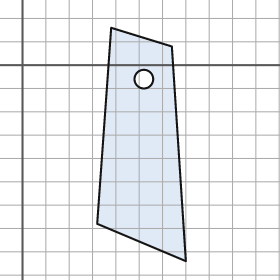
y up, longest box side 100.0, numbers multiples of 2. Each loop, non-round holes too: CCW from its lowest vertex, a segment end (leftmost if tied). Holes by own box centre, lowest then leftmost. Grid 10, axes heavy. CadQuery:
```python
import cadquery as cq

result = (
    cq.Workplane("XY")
    .moveTo(70.0, -84.0)
    .lineTo(64.0, 8.0)
    .lineTo(38.0, 16.0)
    .lineTo(32.0, -68.0)
    .close()
    .moveTo(52.0, -6.0)
    .circle(4.0)
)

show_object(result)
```